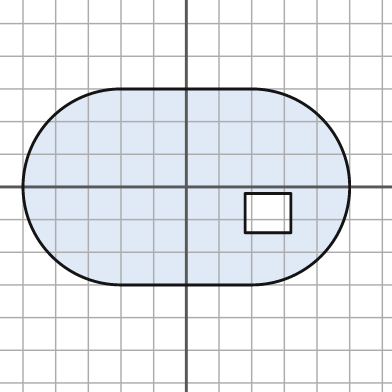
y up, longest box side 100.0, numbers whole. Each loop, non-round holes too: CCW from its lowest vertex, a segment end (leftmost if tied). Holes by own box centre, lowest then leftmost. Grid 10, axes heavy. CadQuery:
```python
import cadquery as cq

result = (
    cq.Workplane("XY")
    .moveTo(-20.0, -30.0)
    .lineTo(20.0, -30.0)
    .threePointArc((50.0, 0.0), (20.0, 30.0))
    .lineTo(-20.0, 30.0)
    .threePointArc((-50.0, 0.0), (-20.0, -30.0))
    .close()
    .moveTo(18.0, -14.0)
    .lineTo(32.0, -14.0)
    .lineTo(32.0, -2.0)
    .lineTo(18.0, -2.0)
    .close()
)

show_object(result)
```